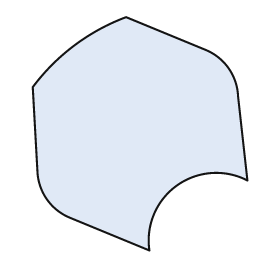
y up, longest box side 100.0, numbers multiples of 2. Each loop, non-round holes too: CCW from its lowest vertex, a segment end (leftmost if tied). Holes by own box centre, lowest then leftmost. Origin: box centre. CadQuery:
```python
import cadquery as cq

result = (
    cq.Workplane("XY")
    .moveTo(4.0, -50.0)
    .threePointArc((16.0, -22.0), (46.0, -20.0))
    .lineTo(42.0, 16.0)
    .threePointArc((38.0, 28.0), (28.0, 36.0))
    .lineTo(-6.0, 50.0)
    .threePointArc((-28.0, 38.0), (-46.0, 20.0))
    .lineTo(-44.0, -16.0)
    .threePointArc((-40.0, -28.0), (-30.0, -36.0))
    .close()
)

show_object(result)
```